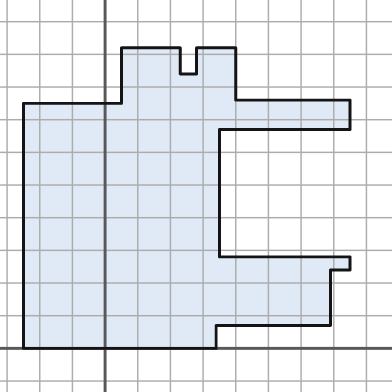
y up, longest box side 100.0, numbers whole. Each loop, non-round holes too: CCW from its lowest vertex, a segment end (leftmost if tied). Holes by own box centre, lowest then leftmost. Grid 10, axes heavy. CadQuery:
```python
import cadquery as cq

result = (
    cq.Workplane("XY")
    .moveTo(-25.0, 0.0)
    .lineTo(34.0, 0.0)
    .lineTo(34.0, 7.0)
    .lineTo(69.0, 7.0)
    .lineTo(69.0, 24.0)
    .lineTo(75.0, 24.0)
    .lineTo(75.0, 28.0)
    .lineTo(35.0, 28.0)
    .lineTo(35.0, 67.0)
    .lineTo(75.0, 67.0)
    .lineTo(75.0, 76.0)
    .lineTo(40.0, 76.0)
    .lineTo(40.0, 92.0)
    .lineTo(28.0, 92.0)
    .lineTo(28.0, 84.0)
    .lineTo(23.0, 84.0)
    .lineTo(23.0, 92.0)
    .lineTo(5.0, 92.0)
    .lineTo(5.0, 75.0)
    .lineTo(-25.0, 75.0)
    .close()
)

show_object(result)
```